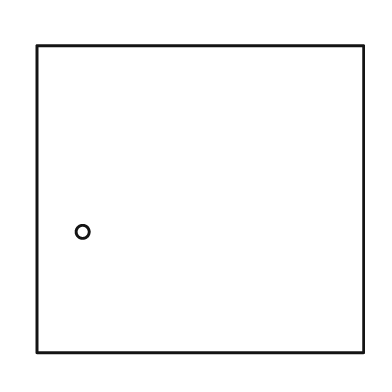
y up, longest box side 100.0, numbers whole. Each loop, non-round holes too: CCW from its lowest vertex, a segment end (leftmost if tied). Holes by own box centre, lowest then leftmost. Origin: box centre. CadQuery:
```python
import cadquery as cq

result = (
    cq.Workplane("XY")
    .moveTo(-50.0, -47.0)
    .lineTo(50.0, -47.0)
    .lineTo(50.0, 47.0)
    .lineTo(-50.0, 47.0)
    .close()
    .moveTo(-36.0, -10.0)
    .circle(2.0)
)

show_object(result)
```